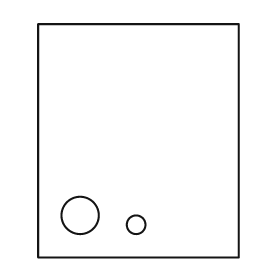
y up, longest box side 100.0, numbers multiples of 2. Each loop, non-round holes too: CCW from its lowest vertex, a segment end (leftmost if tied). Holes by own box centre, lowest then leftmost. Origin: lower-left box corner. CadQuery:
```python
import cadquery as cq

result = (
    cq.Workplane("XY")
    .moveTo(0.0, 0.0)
    .lineTo(86.0, 0.0)
    .lineTo(86.0, 100.0)
    .lineTo(0.0, 100.0)
    .close()
    .moveTo(42.0, 14.0)
    .circle(4.0)
    .moveTo(18.0, 18.0)
    .circle(8.0)
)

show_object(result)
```